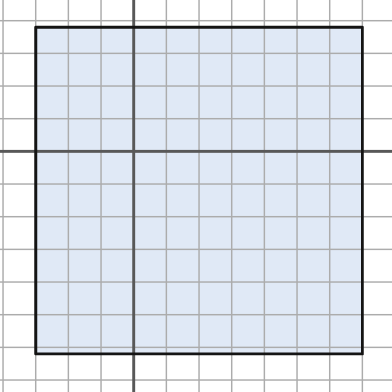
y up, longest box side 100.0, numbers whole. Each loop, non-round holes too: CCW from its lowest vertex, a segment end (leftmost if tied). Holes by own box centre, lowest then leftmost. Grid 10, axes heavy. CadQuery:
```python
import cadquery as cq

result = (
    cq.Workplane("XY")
    .moveTo(-30.0, -62.0)
    .lineTo(70.0, -62.0)
    .lineTo(70.0, 38.0)
    .lineTo(-30.0, 38.0)
    .close()
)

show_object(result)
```